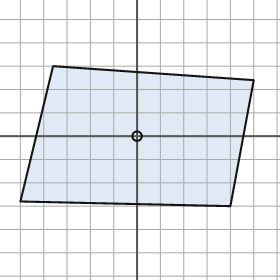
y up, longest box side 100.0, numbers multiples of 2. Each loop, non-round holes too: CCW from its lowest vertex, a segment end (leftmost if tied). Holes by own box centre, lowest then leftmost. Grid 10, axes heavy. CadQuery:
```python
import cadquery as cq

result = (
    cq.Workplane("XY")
    .moveTo(40.0, -30.0)
    .lineTo(50.0, 24.0)
    .lineTo(-36.0, 30.0)
    .lineTo(-50.0, -28.0)
    .close()
    .moveTo(0.0, 0.0)
    .circle(2.0)
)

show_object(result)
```